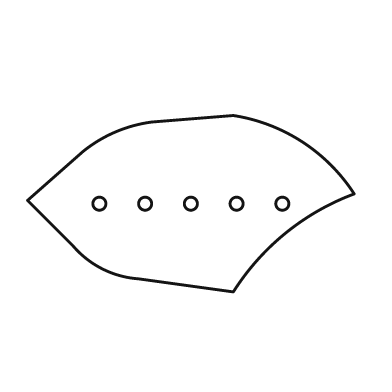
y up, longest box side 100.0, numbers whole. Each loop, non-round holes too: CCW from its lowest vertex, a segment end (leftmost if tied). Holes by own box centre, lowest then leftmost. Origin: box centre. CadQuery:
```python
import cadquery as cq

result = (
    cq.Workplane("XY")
    .moveTo(13.0, -27.0)
    .threePointArc((29.0, -9.0), (50.0, 3.0))
    .threePointArc((34.0, 19.0), (13.0, 27.0))
    .lineTo(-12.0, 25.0)
    .threePointArc((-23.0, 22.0), (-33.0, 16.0))
    .lineTo(-50.0, 1.0)
    .lineTo(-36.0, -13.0)
    .threePointArc((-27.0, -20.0), (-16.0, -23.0))
    .close()
    .moveTo(-28.0, 0.0)
    .circle(2.0)
    .moveTo(-14.0, 0.0)
    .circle(2.0)
    .moveTo(0.0, 0.0)
    .circle(2.0)
    .moveTo(14.0, 0.0)
    .circle(2.0)
    .moveTo(28.0, 0.0)
    .circle(2.0)
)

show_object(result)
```